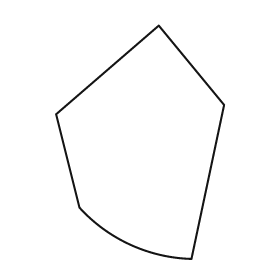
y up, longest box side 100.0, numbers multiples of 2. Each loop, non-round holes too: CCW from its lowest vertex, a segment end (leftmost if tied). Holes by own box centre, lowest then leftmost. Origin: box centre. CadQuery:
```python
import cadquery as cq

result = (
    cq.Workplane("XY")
    .moveTo(22.0, -50.0)
    .lineTo(36.0, 16.0)
    .lineTo(8.0, 50.0)
    .lineTo(-36.0, 12.0)
    .lineTo(-26.0, -28.0)
    .threePointArc((-4.0, -44.0), (22.0, -50.0))
    .close()
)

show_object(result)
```